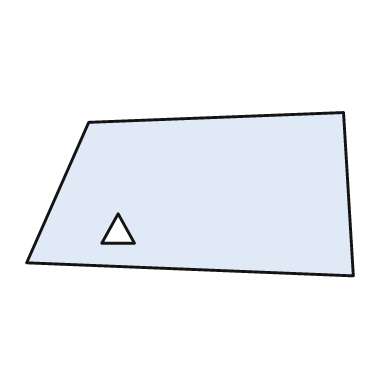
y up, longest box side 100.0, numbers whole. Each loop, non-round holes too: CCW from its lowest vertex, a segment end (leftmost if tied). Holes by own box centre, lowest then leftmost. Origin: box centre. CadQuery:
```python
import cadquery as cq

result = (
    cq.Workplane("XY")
    .moveTo(50.0, -25.0)
    .lineTo(47.0, 25.0)
    .lineTo(-31.0, 22.0)
    .lineTo(-50.0, -21.0)
    .close()
    .moveTo(-27.0, -15.0)
    .lineTo(-17.0, -15.0)
    .lineTo(-22.0, -6.0)
    .close()
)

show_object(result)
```